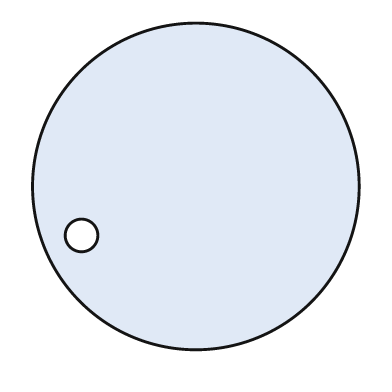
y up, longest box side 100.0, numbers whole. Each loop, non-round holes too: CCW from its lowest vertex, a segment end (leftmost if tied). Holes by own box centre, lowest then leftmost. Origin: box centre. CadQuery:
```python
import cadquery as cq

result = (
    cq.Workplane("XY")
    .moveTo(0.0, 0.0)
    .circle(50.0)
    .moveTo(-35.0, -15.0)
    .circle(5.0)
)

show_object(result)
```